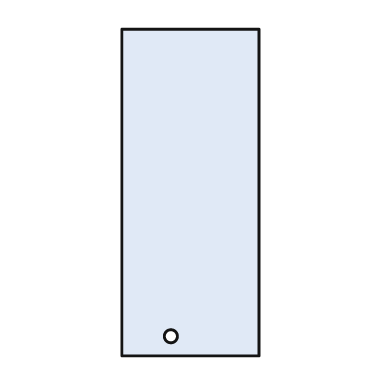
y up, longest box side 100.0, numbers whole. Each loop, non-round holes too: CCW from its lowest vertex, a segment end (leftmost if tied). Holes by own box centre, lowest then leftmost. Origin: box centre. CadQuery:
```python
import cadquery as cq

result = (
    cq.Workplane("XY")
    .moveTo(-21.0, -50.0)
    .lineTo(21.0, -50.0)
    .lineTo(21.0, 50.0)
    .lineTo(-21.0, 50.0)
    .close()
    .moveTo(-6.0, -44.0)
    .circle(2.0)
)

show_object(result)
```